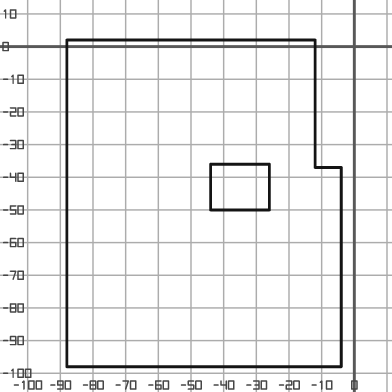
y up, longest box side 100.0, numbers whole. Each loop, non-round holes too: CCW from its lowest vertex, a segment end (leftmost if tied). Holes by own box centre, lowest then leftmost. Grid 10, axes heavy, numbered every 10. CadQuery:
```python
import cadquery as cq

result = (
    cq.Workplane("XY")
    .moveTo(-88.0, -98.0)
    .lineTo(-4.0, -98.0)
    .lineTo(-4.0, -37.0)
    .lineTo(-12.0, -37.0)
    .lineTo(-12.0, 2.0)
    .lineTo(-88.0, 2.0)
    .close()
    .moveTo(-44.0, -50.0)
    .lineTo(-26.0, -50.0)
    .lineTo(-26.0, -36.0)
    .lineTo(-44.0, -36.0)
    .close()
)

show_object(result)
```